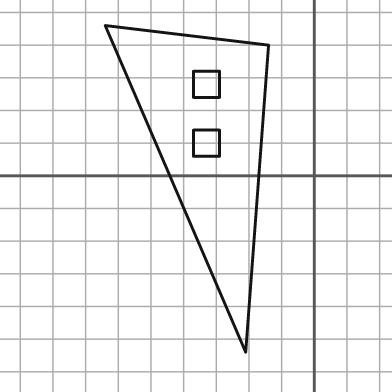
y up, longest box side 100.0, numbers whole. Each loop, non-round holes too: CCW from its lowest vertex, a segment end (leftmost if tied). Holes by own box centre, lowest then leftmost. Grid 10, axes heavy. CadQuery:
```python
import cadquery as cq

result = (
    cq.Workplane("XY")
    .moveTo(-21.0, -54.0)
    .lineTo(-14.0, 40.0)
    .lineTo(-64.0, 46.0)
    .close()
    .moveTo(-37.0, 6.0)
    .lineTo(-29.0, 6.0)
    .lineTo(-29.0, 14.0)
    .lineTo(-37.0, 14.0)
    .close()
    .moveTo(-37.0, 24.0)
    .lineTo(-29.0, 24.0)
    .lineTo(-29.0, 32.0)
    .lineTo(-37.0, 32.0)
    .close()
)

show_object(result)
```